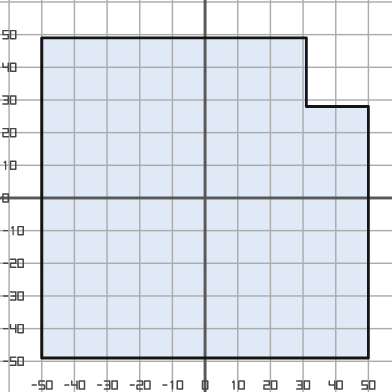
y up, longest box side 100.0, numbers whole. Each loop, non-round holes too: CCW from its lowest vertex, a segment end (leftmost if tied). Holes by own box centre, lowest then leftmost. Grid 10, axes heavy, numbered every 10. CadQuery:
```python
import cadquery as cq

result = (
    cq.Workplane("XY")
    .moveTo(-50.0, -49.0)
    .lineTo(50.0, -49.0)
    .lineTo(50.0, 28.0)
    .lineTo(31.0, 28.0)
    .lineTo(31.0, 49.0)
    .lineTo(-50.0, 49.0)
    .close()
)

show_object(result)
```